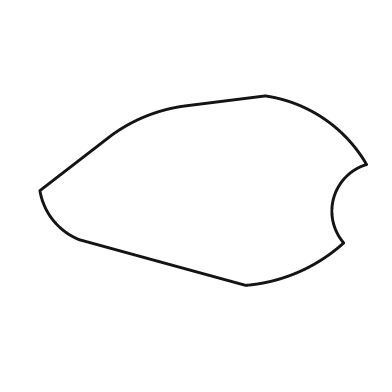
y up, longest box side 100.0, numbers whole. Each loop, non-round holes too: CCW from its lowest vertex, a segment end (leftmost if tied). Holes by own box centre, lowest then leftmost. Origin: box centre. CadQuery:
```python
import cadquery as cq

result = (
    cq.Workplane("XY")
    .moveTo(13.0, -29.0)
    .threePointArc((29.0, -25.0), (43.0, -16.0))
    .threePointArc((40.0, -2.0), (50.0, 8.0))
    .threePointArc((37.0, 22.0), (19.0, 29.0))
    .lineTo(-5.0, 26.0)
    .threePointArc((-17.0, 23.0), (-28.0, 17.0))
    .lineTo(-50.0, 0.0)
    .threePointArc((-46.0, -9.0), (-38.0, -15.0))
    .close()
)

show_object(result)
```